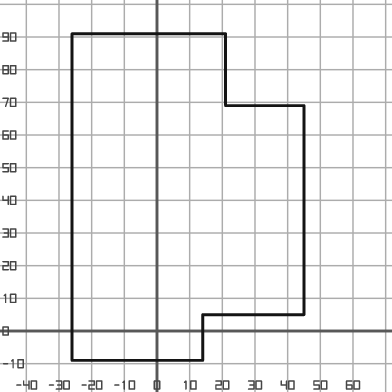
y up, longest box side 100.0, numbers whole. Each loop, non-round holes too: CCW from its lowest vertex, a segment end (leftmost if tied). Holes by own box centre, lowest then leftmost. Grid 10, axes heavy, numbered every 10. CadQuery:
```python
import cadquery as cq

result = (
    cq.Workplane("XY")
    .moveTo(-26.0, -9.0)
    .lineTo(14.0, -9.0)
    .lineTo(14.0, 5.0)
    .lineTo(45.0, 5.0)
    .lineTo(45.0, 69.0)
    .lineTo(21.0, 69.0)
    .lineTo(21.0, 91.0)
    .lineTo(-26.0, 91.0)
    .close()
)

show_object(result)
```